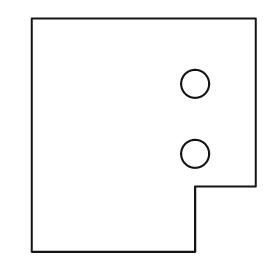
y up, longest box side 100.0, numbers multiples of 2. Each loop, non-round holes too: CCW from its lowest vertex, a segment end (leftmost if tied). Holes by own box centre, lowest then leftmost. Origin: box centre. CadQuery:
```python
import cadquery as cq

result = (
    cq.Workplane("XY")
    .moveTo(-48.0, -50.0)
    .lineTo(22.0, -50.0)
    .lineTo(22.0, -22.0)
    .lineTo(48.0, -22.0)
    .lineTo(48.0, 50.0)
    .lineTo(-48.0, 50.0)
    .close()
    .moveTo(22.0, -8.0)
    .circle(6.0)
    .moveTo(22.0, 22.0)
    .circle(6.0)
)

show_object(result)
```